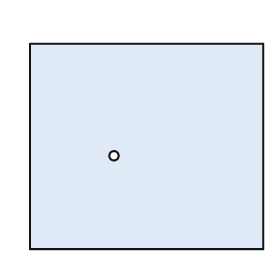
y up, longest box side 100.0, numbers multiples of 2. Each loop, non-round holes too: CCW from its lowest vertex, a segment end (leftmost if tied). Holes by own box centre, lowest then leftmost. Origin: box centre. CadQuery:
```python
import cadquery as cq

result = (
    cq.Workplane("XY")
    .moveTo(-50.0, -44.0)
    .lineTo(50.0, -44.0)
    .lineTo(50.0, 44.0)
    .lineTo(-50.0, 44.0)
    .close()
    .moveTo(-14.0, -4.0)
    .circle(2.0)
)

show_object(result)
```